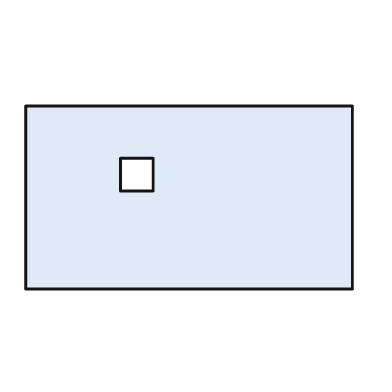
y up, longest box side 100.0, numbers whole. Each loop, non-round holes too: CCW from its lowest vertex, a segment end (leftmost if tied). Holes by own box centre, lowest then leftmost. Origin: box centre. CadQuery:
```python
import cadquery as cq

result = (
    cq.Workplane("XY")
    .moveTo(-50.0, -28.0)
    .lineTo(50.0, -28.0)
    .lineTo(50.0, 28.0)
    .lineTo(-50.0, 28.0)
    .close()
    .moveTo(-21.0, 2.0)
    .lineTo(-11.0, 2.0)
    .lineTo(-11.0, 12.0)
    .lineTo(-21.0, 12.0)
    .close()
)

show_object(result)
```